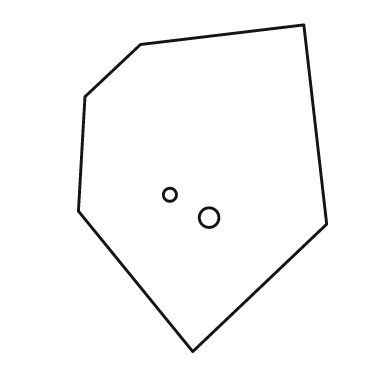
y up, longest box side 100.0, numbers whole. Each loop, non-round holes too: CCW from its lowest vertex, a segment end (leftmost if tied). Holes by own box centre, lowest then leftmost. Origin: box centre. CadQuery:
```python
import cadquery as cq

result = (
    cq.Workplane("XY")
    .moveTo(-3.0, -50.0)
    .lineTo(38.0, -11.0)
    .lineTo(31.0, 50.0)
    .lineTo(-19.0, 44.0)
    .lineTo(-36.0, 28.0)
    .lineTo(-38.0, -7.0)
    .close()
    .moveTo(2.0, -9.0)
    .circle(3.0)
    .moveTo(-10.0, -2.0)
    .circle(2.0)
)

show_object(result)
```